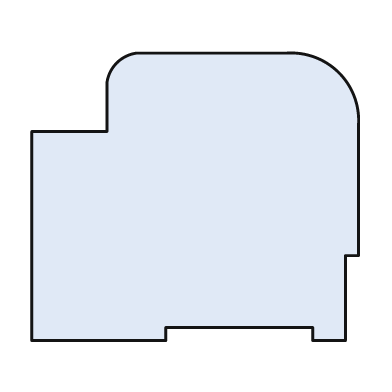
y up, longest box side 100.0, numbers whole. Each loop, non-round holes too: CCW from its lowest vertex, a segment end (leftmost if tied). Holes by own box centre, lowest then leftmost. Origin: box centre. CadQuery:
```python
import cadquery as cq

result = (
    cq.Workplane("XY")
    .moveTo(-50.0, -44.0)
    .lineTo(-9.0, -44.0)
    .lineTo(-9.0, -40.0)
    .lineTo(36.0, -40.0)
    .lineTo(36.0, -44.0)
    .lineTo(46.0, -44.0)
    .lineTo(46.0, -18.0)
    .lineTo(50.0, -18.0)
    .lineTo(50.0, 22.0)
    .threePointArc((44.0, 38.0), (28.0, 44.0))
    .lineTo(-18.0, 44.0)
    .threePointArc((-24.0, 41.0), (-27.0, 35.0))
    .lineTo(-27.0, 20.0)
    .lineTo(-50.0, 20.0)
    .close()
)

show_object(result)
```